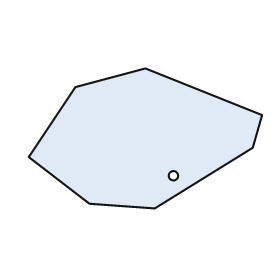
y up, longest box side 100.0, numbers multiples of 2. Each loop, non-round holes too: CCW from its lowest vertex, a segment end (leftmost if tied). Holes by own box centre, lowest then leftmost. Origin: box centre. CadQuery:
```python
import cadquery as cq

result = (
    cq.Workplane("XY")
    .moveTo(4.0, -30.0)
    .lineTo(46.0, -4.0)
    .lineTo(50.0, 10.0)
    .lineTo(0.0, 30.0)
    .lineTo(-30.0, 22.0)
    .lineTo(-50.0, -8.0)
    .lineTo(-24.0, -28.0)
    .close()
    .moveTo(12.0, -16.0)
    .circle(2.0)
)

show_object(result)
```